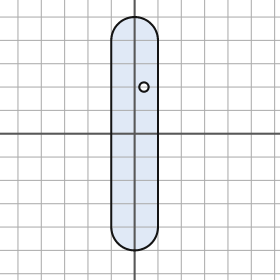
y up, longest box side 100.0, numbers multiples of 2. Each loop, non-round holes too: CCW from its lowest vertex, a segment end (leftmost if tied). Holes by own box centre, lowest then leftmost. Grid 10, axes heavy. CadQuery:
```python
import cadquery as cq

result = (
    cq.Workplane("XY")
    .moveTo(-10.0, -40.0)
    .threePointArc((0.0, -50.0), (10.0, -40.0))
    .lineTo(10.0, 40.0)
    .threePointArc((0.0, 50.0), (-10.0, 40.0))
    .close()
    .moveTo(4.0, 20.0)
    .circle(2.0)
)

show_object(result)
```